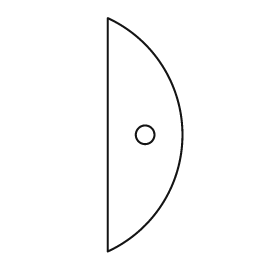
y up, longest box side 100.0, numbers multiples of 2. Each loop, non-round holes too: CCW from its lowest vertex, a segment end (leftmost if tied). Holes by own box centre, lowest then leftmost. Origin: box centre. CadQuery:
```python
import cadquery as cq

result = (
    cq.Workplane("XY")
    .moveTo(-16.0, -50.0)
    .threePointArc((16.0, 0.0), (-16.0, 50.0))
    .close()
    .moveTo(0.0, 0.0)
    .circle(4.0)
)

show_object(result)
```